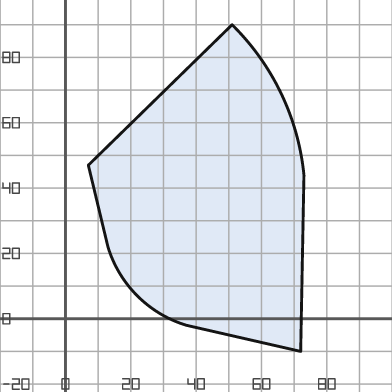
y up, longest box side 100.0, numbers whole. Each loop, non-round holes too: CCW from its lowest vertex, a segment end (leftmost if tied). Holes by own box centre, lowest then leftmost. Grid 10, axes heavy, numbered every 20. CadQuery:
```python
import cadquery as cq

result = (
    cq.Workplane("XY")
    .moveTo(72.0, -10.0)
    .lineTo(73.0, 44.0)
    .threePointArc((66.0, 69.0), (51.0, 90.0))
    .lineTo(7.0, 47.0)
    .lineTo(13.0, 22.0)
    .threePointArc((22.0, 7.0), (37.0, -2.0))
    .close()
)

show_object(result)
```